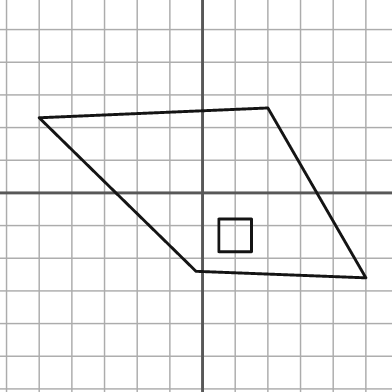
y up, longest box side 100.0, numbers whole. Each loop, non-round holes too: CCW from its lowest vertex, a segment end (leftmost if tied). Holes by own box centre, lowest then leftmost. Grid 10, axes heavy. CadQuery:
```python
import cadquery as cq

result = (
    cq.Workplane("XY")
    .moveTo(50.0, -26.0)
    .lineTo(20.0, 26.0)
    .lineTo(-50.0, 23.0)
    .lineTo(-2.0, -24.0)
    .close()
    .moveTo(5.0, -18.0)
    .lineTo(15.0, -18.0)
    .lineTo(15.0, -8.0)
    .lineTo(5.0, -8.0)
    .close()
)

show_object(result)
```